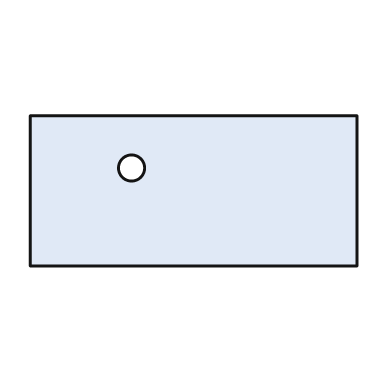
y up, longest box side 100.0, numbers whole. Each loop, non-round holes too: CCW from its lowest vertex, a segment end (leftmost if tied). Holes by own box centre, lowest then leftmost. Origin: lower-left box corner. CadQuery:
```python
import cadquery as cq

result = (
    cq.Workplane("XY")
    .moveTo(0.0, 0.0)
    .lineTo(100.0, 0.0)
    .lineTo(100.0, 46.0)
    .lineTo(0.0, 46.0)
    .close()
    .moveTo(31.0, 30.0)
    .circle(4.0)
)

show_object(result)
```